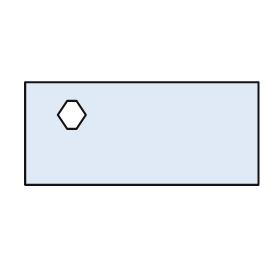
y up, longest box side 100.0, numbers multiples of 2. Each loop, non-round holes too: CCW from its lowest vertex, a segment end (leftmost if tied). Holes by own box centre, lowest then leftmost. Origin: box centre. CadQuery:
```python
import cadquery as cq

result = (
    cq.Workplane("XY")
    .moveTo(-50.0, -22.0)
    .lineTo(50.0, -22.0)
    .lineTo(50.0, 22.0)
    .lineTo(-50.0, 22.0)
    .close()
    .moveTo(-32.0, 2.0)
    .lineTo(-28.0, 2.0)
    .lineTo(-24.0, 8.0)
    .lineTo(-28.0, 14.0)
    .lineTo(-32.0, 14.0)
    .lineTo(-36.0, 8.0)
    .close()
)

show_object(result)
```